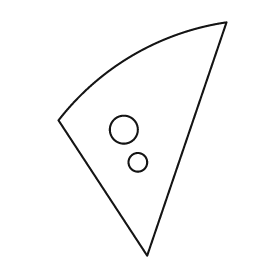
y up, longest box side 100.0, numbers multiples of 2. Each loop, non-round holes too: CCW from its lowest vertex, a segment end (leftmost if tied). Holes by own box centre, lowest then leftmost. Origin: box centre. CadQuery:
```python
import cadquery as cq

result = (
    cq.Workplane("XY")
    .moveTo(2.0, -50.0)
    .lineTo(36.0, 50.0)
    .threePointArc((-4.0, 36.0), (-36.0, 8.0))
    .close()
    .moveTo(-2.0, -10.0)
    .circle(4.0)
    .moveTo(-8.0, 4.0)
    .circle(6.0)
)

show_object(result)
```